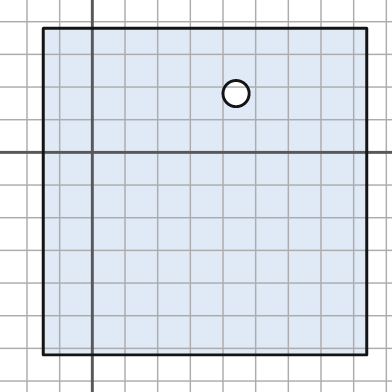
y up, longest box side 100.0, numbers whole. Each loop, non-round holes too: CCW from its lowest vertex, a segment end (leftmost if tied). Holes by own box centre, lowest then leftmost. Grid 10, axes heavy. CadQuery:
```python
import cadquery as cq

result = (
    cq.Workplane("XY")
    .moveTo(-15.0, -62.0)
    .lineTo(84.0, -62.0)
    .lineTo(84.0, 38.0)
    .lineTo(-15.0, 38.0)
    .close()
    .moveTo(44.0, 18.0)
    .circle(4.0)
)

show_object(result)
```